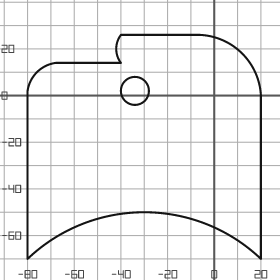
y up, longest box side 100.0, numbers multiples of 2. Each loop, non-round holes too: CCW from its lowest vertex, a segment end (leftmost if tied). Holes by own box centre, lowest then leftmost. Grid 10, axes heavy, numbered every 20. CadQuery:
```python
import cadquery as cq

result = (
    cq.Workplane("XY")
    .moveTo(-80.0, -70.0)
    .threePointArc((-30.0, -50.0), (20.0, -70.0))
    .lineTo(20.0, 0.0)
    .threePointArc((12.0, 18.0), (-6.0, 26.0))
    .lineTo(-40.0, 26.0)
    .threePointArc((-42.0, 20.0), (-40.0, 14.0))
    .lineTo(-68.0, 14.0)
    .threePointArc((-76.0, 10.0), (-80.0, 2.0))
    .close()
    .moveTo(-34.0, 2.0)
    .circle(6.0)
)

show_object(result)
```